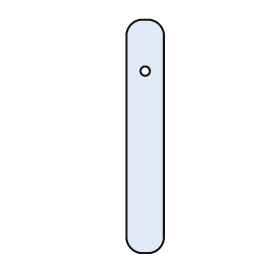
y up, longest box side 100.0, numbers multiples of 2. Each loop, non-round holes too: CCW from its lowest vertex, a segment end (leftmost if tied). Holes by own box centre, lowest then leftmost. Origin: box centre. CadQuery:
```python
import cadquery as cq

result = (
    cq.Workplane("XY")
    .moveTo(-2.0, -50.0)
    .lineTo(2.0, -50.0)
    .threePointArc((6.0, -48.0), (8.0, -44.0))
    .lineTo(8.0, 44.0)
    .threePointArc((6.0, 48.0), (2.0, 50.0))
    .lineTo(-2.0, 50.0)
    .threePointArc((-6.0, 48.0), (-8.0, 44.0))
    .lineTo(-8.0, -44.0)
    .threePointArc((-6.0, -48.0), (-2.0, -50.0))
    .close()
    .moveTo(0.0, 28.0)
    .circle(2.0)
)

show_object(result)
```